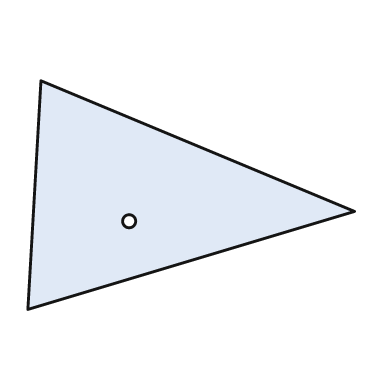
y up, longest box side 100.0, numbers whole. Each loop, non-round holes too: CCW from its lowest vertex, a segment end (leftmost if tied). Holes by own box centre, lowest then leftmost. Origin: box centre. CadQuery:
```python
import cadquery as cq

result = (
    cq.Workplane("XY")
    .moveTo(-50.0, -35.0)
    .lineTo(50.0, -5.0)
    .lineTo(-46.0, 35.0)
    .close()
    .moveTo(-19.0, -8.0)
    .circle(2.0)
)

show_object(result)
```